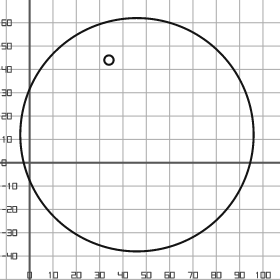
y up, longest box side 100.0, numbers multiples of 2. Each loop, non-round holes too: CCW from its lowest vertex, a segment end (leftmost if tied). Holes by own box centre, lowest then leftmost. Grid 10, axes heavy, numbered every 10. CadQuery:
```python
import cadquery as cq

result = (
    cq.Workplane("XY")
    .moveTo(46.0, 12.0)
    .circle(50.0)
    .moveTo(34.0, 44.0)
    .circle(2.0)
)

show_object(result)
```